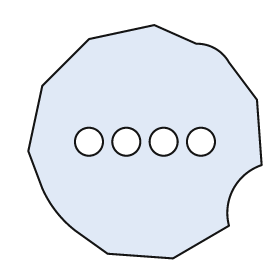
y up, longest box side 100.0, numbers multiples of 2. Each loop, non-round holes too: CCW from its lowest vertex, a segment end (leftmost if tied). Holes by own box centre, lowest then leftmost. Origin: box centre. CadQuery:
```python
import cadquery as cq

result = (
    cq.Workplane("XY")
    .moveTo(12.0, -50.0)
    .lineTo(36.0, -36.0)
    .threePointArc((38.0, -20.0), (50.0, -10.0))
    .lineTo(48.0, 18.0)
    .lineTo(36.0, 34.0)
    .threePointArc((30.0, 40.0), (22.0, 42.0))
    .lineTo(4.0, 50.0)
    .lineTo(-24.0, 44.0)
    .lineTo(-44.0, 24.0)
    .lineTo(-50.0, -4.0)
    .lineTo(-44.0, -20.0)
    .threePointArc((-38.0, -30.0), (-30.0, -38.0))
    .lineTo(-16.0, -48.0)
    .close()
    .moveTo(-24.0, 0.0)
    .circle(6.0)
    .moveTo(-8.0, 0.0)
    .circle(6.0)
    .moveTo(8.0, 0.0)
    .circle(6.0)
    .moveTo(24.0, 0.0)
    .circle(6.0)
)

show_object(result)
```